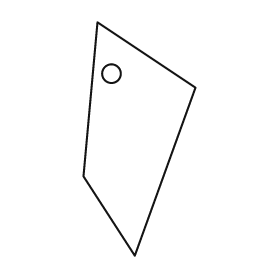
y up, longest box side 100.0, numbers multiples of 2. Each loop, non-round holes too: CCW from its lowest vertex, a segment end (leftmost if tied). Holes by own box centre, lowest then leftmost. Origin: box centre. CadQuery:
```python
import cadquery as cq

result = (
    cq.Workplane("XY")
    .moveTo(-2.0, -50.0)
    .lineTo(24.0, 22.0)
    .lineTo(-18.0, 50.0)
    .lineTo(-24.0, -16.0)
    .close()
    .moveTo(-12.0, 28.0)
    .circle(4.0)
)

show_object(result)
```